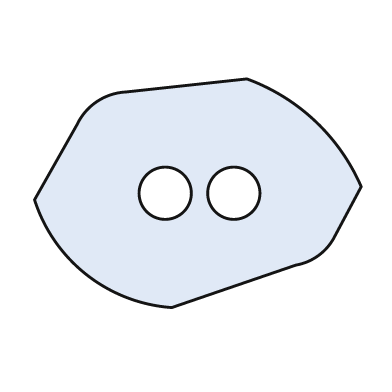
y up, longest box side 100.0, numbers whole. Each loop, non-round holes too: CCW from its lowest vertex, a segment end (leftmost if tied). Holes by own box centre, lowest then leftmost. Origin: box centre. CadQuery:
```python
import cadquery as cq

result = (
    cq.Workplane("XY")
    .moveTo(-8.0, -35.0)
    .lineTo(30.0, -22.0)
    .threePointArc((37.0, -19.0), (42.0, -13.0))
    .lineTo(50.0, 2.0)
    .threePointArc((36.0, 22.0), (15.0, 35.0))
    .lineTo(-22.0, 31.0)
    .threePointArc((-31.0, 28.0), (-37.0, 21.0))
    .lineTo(-50.0, -2.0)
    .threePointArc((-34.0, -25.0), (-8.0, -35.0))
    .close()
    .moveTo(-10.0, 0.0)
    .circle(8.0)
    .moveTo(11.0, 0.0)
    .circle(8.0)
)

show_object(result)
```